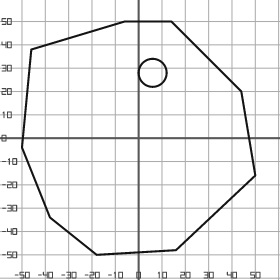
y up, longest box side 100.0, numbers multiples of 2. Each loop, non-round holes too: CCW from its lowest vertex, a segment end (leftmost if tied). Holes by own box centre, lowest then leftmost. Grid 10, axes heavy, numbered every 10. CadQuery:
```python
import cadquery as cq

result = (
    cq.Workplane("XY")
    .moveTo(-18.0, -50.0)
    .lineTo(16.0, -48.0)
    .lineTo(50.0, -16.0)
    .lineTo(44.0, 20.0)
    .lineTo(14.0, 50.0)
    .lineTo(-6.0, 50.0)
    .lineTo(-46.0, 38.0)
    .lineTo(-50.0, -4.0)
    .lineTo(-38.0, -34.0)
    .close()
    .moveTo(6.0, 28.0)
    .circle(6.0)
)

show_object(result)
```